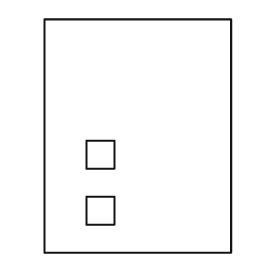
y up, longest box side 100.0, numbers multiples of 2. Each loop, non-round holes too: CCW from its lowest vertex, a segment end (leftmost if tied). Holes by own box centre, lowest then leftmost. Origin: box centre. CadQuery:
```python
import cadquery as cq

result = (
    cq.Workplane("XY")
    .moveTo(-40.0, -50.0)
    .lineTo(40.0, -50.0)
    .lineTo(40.0, 50.0)
    .lineTo(-40.0, 50.0)
    .close()
    .moveTo(-22.0, -38.0)
    .lineTo(-10.0, -38.0)
    .lineTo(-10.0, -26.0)
    .lineTo(-22.0, -26.0)
    .close()
    .moveTo(-22.0, -14.0)
    .lineTo(-10.0, -14.0)
    .lineTo(-10.0, -2.0)
    .lineTo(-22.0, -2.0)
    .close()
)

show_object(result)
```